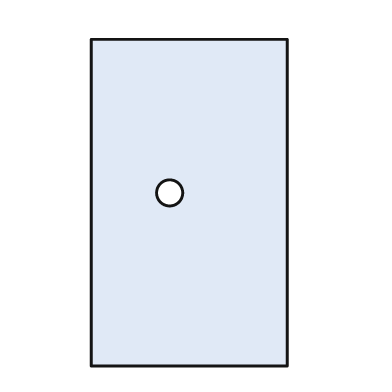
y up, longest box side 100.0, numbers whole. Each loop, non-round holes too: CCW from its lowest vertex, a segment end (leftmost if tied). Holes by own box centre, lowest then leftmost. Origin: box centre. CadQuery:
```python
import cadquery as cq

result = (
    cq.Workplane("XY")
    .moveTo(-30.0, -50.0)
    .lineTo(30.0, -50.0)
    .lineTo(30.0, 50.0)
    .lineTo(-30.0, 50.0)
    .close()
    .moveTo(-6.0, 3.0)
    .circle(4.0)
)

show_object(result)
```